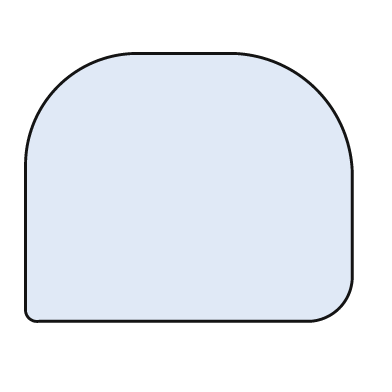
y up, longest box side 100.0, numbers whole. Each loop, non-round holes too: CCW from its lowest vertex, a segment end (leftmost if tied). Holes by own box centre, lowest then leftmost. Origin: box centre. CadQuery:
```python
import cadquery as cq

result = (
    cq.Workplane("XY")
    .moveTo(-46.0, -41.0)
    .lineTo(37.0, -41.0)
    .threePointArc((46.0, -37.0), (50.0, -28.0))
    .lineTo(50.0, 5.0)
    .threePointArc((39.0, 30.0), (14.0, 41.0))
    .lineTo(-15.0, 41.0)
    .threePointArc((-40.0, 31.0), (-50.0, 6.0))
    .lineTo(-50.0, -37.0)
    .threePointArc((-49.0, -40.0), (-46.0, -41.0))
    .close()
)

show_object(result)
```